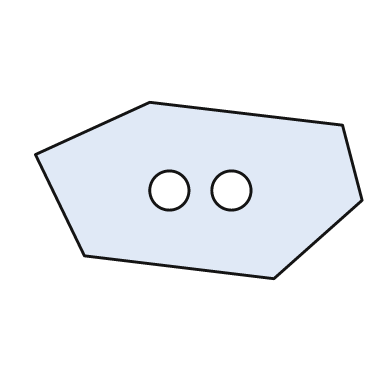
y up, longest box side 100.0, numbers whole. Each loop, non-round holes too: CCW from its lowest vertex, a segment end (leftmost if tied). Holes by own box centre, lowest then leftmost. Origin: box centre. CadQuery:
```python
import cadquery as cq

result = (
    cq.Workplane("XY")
    .moveTo(23.0, -27.0)
    .lineTo(50.0, -3.0)
    .lineTo(44.0, 20.0)
    .lineTo(-15.0, 27.0)
    .lineTo(-50.0, 11.0)
    .lineTo(-35.0, -20.0)
    .close()
    .moveTo(-9.0, 0.0)
    .circle(6.0)
    .moveTo(10.0, 0.0)
    .circle(6.0)
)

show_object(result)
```